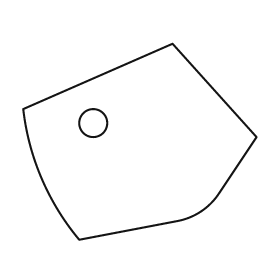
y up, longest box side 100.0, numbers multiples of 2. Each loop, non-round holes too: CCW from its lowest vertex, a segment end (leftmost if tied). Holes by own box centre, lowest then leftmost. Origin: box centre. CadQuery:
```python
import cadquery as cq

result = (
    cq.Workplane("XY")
    .moveTo(-26.0, -42.0)
    .lineTo(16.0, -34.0)
    .threePointArc((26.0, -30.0), (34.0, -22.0))
    .lineTo(50.0, 2.0)
    .lineTo(14.0, 42.0)
    .lineTo(-50.0, 14.0)
    .threePointArc((-42.0, -16.0), (-26.0, -42.0))
    .close()
    .moveTo(-20.0, 8.0)
    .circle(6.0)
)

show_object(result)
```